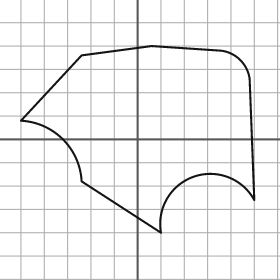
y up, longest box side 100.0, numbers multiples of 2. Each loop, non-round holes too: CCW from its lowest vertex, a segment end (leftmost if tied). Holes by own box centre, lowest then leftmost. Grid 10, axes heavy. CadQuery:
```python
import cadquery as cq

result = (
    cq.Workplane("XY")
    .moveTo(10.0, -40.0)
    .threePointArc((24.0, -16.0), (50.0, -26.0))
    .lineTo(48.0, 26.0)
    .threePointArc((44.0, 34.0), (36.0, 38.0))
    .lineTo(6.0, 40.0)
    .lineTo(-24.0, 36.0)
    .lineTo(-50.0, 8.0)
    .threePointArc((-32.0, 0.0), (-24.0, -18.0))
    .close()
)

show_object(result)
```